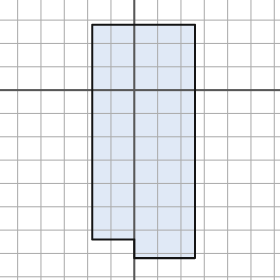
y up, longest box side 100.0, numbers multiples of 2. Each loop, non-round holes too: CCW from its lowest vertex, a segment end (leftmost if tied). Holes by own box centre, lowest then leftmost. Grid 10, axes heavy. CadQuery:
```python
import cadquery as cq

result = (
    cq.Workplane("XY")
    .moveTo(0.0, -72.0)
    .lineTo(26.0, -72.0)
    .lineTo(26.0, 28.0)
    .lineTo(-18.0, 28.0)
    .lineTo(-18.0, -64.0)
    .lineTo(0.0, -64.0)
    .close()
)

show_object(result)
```